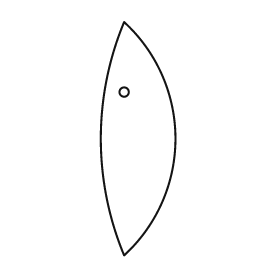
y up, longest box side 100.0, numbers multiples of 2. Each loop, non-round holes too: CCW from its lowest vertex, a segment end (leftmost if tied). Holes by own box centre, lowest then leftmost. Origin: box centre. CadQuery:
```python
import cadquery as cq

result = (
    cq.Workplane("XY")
    .moveTo(-6.0, -50.0)
    .threePointArc((16.0, 0.0), (-6.0, 50.0))
    .threePointArc((-16.0, 0.0), (-6.0, -50.0))
    .close()
    .moveTo(-6.0, 20.0)
    .circle(2.0)
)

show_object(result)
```